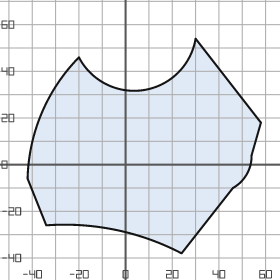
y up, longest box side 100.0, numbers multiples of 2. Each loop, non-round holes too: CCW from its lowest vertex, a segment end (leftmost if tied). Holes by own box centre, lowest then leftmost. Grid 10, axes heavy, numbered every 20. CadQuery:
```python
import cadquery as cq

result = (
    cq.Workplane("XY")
    .moveTo(24.0, -38.0)
    .lineTo(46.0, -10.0)
    .threePointArc((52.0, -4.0), (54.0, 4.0))
    .lineTo(58.0, 18.0)
    .lineTo(30.0, 54.0)
    .threePointArc((8.0, 32.0), (-20.0, 46.0))
    .threePointArc((-36.0, 22.0), (-42.0, -6.0))
    .lineTo(-34.0, -26.0)
    .threePointArc((-4.0, -28.0), (24.0, -38.0))
    .close()
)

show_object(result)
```